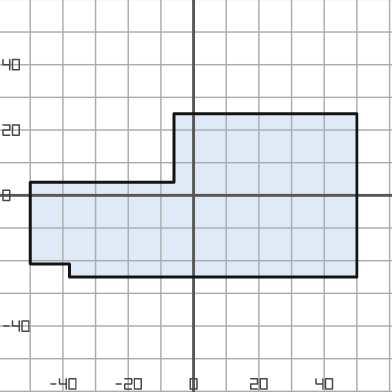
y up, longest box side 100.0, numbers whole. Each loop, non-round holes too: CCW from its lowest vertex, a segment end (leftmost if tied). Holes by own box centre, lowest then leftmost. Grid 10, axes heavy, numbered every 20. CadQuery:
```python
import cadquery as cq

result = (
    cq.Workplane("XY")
    .moveTo(-38.0, -25.0)
    .lineTo(50.0, -25.0)
    .lineTo(50.0, 25.0)
    .lineTo(-6.0, 25.0)
    .lineTo(-6.0, 4.0)
    .lineTo(-50.0, 4.0)
    .lineTo(-50.0, -21.0)
    .lineTo(-38.0, -21.0)
    .close()
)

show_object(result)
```